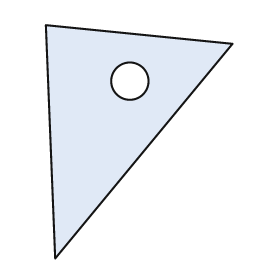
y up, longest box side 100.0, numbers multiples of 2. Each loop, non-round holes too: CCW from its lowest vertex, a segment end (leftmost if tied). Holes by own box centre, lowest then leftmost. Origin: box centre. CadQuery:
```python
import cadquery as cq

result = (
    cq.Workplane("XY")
    .moveTo(-36.0, -50.0)
    .lineTo(40.0, 42.0)
    .lineTo(-40.0, 50.0)
    .close()
    .moveTo(-4.0, 26.0)
    .circle(8.0)
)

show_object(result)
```